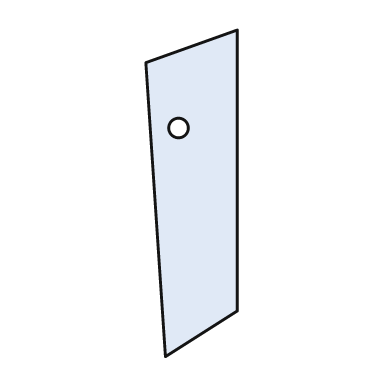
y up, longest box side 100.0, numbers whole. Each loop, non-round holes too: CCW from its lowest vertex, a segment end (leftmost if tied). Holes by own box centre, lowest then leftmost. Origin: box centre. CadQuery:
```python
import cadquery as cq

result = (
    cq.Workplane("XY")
    .moveTo(-8.0, -50.0)
    .lineTo(14.0, -36.0)
    .lineTo(14.0, 50.0)
    .lineTo(-14.0, 40.0)
    .close()
    .moveTo(-4.0, 20.0)
    .circle(3.0)
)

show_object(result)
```